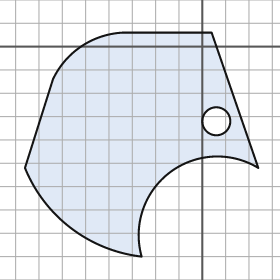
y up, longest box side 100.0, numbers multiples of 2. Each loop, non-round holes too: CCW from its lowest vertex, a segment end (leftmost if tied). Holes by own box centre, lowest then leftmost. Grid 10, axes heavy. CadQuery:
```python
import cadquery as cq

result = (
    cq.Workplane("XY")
    .moveTo(-26.0, -90.0)
    .threePointArc((-14.0, -54.0), (24.0, -52.0))
    .lineTo(4.0, 6.0)
    .lineTo(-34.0, 6.0)
    .threePointArc((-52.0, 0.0), (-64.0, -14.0))
    .lineTo(-76.0, -52.0)
    .threePointArc((-56.0, -78.0), (-26.0, -90.0))
    .close()
    .moveTo(6.0, -32.0)
    .circle(6.0)
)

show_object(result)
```